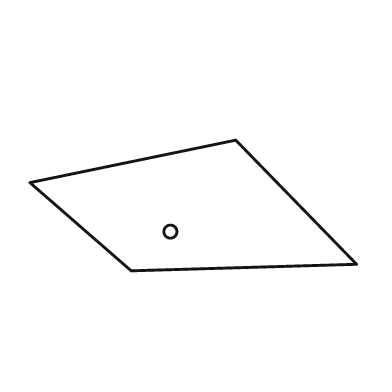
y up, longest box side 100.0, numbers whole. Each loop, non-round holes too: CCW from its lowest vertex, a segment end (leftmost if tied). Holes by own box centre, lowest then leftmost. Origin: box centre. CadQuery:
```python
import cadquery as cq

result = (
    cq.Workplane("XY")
    .moveTo(-19.0, -20.0)
    .lineTo(50.0, -18.0)
    .lineTo(13.0, 20.0)
    .lineTo(-50.0, 7.0)
    .close()
    .moveTo(-7.0, -8.0)
    .circle(2.0)
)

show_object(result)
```